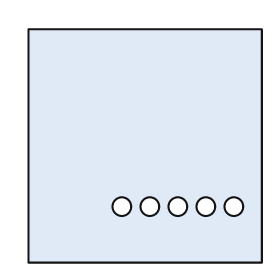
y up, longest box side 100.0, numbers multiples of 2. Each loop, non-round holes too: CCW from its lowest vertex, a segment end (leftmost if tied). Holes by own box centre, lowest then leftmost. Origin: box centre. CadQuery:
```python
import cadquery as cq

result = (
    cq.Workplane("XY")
    .moveTo(-50.0, -50.0)
    .lineTo(50.0, -50.0)
    .lineTo(50.0, 50.0)
    .lineTo(-50.0, 50.0)
    .close()
    .moveTo(-10.0, -26.0)
    .circle(4.0)
    .moveTo(2.0, -26.0)
    .circle(4.0)
    .moveTo(14.0, -26.0)
    .circle(4.0)
    .moveTo(26.0, -26.0)
    .circle(4.0)
    .moveTo(38.0, -26.0)
    .circle(4.0)
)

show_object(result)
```